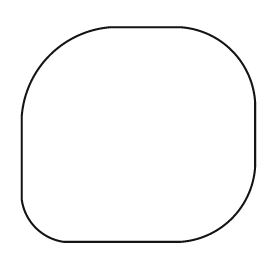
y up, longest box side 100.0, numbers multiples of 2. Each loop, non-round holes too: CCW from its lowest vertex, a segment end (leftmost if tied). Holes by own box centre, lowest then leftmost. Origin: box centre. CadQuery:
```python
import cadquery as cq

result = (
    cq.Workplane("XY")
    .moveTo(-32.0, -46.0)
    .lineTo(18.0, -46.0)
    .threePointArc((40.0, -36.0), (50.0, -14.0))
    .lineTo(50.0, 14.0)
    .threePointArc((40.0, 36.0), (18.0, 46.0))
    .lineTo(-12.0, 46.0)
    .threePointArc((-38.0, 34.0), (-50.0, 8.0))
    .lineTo(-50.0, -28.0)
    .threePointArc((-44.0, -40.0), (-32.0, -46.0))
    .close()
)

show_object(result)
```